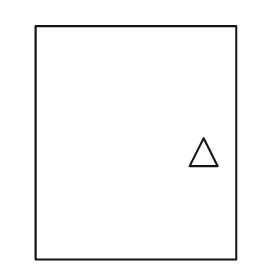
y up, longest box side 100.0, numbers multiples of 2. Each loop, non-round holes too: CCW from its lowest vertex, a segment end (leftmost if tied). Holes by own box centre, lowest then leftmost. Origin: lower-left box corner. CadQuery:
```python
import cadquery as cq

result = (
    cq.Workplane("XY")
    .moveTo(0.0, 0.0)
    .lineTo(86.0, 0.0)
    .lineTo(86.0, 100.0)
    .lineTo(0.0, 100.0)
    .close()
    .moveTo(66.0, 40.0)
    .lineTo(78.0, 40.0)
    .lineTo(72.0, 52.0)
    .close()
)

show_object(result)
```